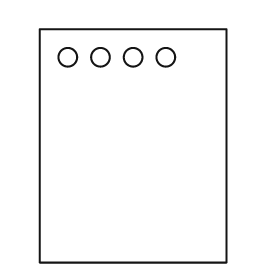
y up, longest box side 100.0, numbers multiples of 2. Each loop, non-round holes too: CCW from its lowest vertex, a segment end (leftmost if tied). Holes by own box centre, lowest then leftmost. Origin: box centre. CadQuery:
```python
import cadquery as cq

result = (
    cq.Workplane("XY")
    .moveTo(-40.0, -50.0)
    .lineTo(40.0, -50.0)
    .lineTo(40.0, 50.0)
    .lineTo(-40.0, 50.0)
    .close()
    .moveTo(-28.0, 38.0)
    .circle(4.0)
    .moveTo(-14.0, 38.0)
    .circle(4.0)
    .moveTo(0.0, 38.0)
    .circle(4.0)
    .moveTo(14.0, 38.0)
    .circle(4.0)
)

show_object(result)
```